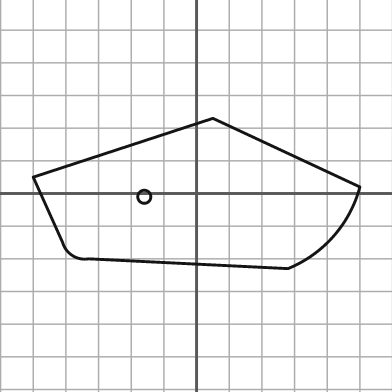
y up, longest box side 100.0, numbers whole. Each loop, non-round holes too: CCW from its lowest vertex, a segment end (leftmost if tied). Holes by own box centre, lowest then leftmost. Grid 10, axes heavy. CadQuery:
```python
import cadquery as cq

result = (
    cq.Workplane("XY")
    .moveTo(28.0, -23.0)
    .threePointArc((42.0, -13.0), (50.0, 2.0))
    .lineTo(5.0, 23.0)
    .lineTo(-50.0, 5.0)
    .lineTo(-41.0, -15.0)
    .threePointArc((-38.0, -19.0), (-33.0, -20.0))
    .close()
    .moveTo(-16.0, -1.0)
    .circle(2.0)
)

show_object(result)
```